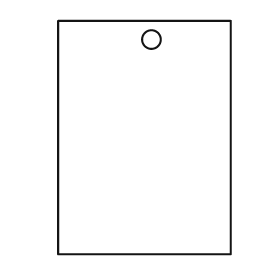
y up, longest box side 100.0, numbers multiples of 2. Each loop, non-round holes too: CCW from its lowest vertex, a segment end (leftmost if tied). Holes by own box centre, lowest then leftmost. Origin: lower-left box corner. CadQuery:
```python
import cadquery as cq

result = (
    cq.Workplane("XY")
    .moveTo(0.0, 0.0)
    .lineTo(74.0, 0.0)
    .lineTo(74.0, 100.0)
    .lineTo(0.0, 100.0)
    .close()
    .moveTo(40.0, 92.0)
    .circle(4.0)
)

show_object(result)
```